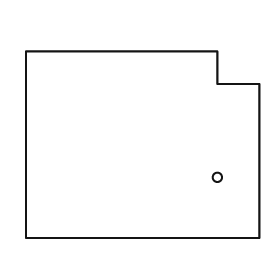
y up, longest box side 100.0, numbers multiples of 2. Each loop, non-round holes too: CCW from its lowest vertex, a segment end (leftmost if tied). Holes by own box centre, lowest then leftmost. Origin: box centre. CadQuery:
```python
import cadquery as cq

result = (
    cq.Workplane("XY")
    .moveTo(-50.0, -40.0)
    .lineTo(50.0, -40.0)
    .lineTo(50.0, 26.0)
    .lineTo(32.0, 26.0)
    .lineTo(32.0, 40.0)
    .lineTo(-50.0, 40.0)
    .close()
    .moveTo(32.0, -14.0)
    .circle(2.0)
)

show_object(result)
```